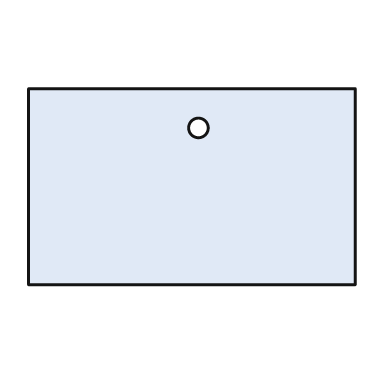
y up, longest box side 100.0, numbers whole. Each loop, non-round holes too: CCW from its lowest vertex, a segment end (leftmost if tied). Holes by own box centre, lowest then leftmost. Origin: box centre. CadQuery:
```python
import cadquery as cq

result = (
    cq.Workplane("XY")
    .moveTo(-50.0, -30.0)
    .lineTo(50.0, -30.0)
    .lineTo(50.0, 30.0)
    .lineTo(-50.0, 30.0)
    .close()
    .moveTo(2.0, 18.0)
    .circle(3.0)
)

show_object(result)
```